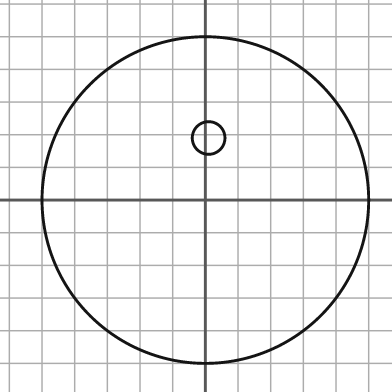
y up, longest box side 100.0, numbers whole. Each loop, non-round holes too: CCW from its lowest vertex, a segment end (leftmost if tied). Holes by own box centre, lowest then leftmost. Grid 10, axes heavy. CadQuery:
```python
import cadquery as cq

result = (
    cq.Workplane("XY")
    .moveTo(0.0, 0.0)
    .circle(50.0)
    .moveTo(1.0, 19.0)
    .circle(5.0)
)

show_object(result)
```